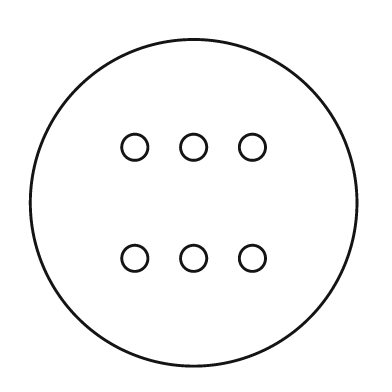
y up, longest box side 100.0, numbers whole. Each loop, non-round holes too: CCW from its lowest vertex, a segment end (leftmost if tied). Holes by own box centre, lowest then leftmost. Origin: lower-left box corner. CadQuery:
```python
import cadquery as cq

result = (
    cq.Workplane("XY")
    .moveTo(50.0, 50.0)
    .circle(50.0)
    .moveTo(32.0, 33.0)
    .circle(4.0)
    .moveTo(50.0, 33.0)
    .circle(4.0)
    .moveTo(68.0, 33.0)
    .circle(4.0)
    .moveTo(32.0, 67.0)
    .circle(4.0)
    .moveTo(50.0, 67.0)
    .circle(4.0)
    .moveTo(68.0, 67.0)
    .circle(4.0)
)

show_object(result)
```